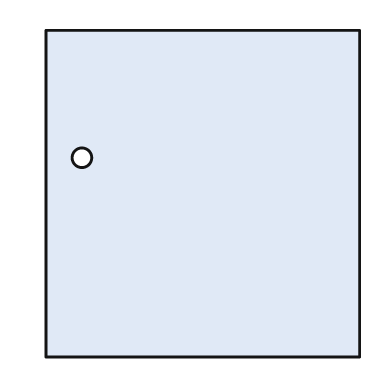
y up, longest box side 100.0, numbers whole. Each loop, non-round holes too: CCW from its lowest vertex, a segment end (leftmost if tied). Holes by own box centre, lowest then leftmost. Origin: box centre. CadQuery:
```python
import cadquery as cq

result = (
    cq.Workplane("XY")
    .moveTo(-48.0, -50.0)
    .lineTo(48.0, -50.0)
    .lineTo(48.0, 50.0)
    .lineTo(-48.0, 50.0)
    .close()
    .moveTo(-37.0, 11.0)
    .circle(3.0)
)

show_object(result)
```